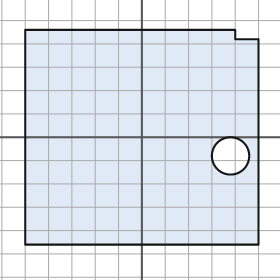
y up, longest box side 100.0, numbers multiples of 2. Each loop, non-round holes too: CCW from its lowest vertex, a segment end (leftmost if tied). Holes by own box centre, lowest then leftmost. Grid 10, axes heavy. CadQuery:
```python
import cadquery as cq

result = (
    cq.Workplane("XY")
    .moveTo(-50.0, -46.0)
    .lineTo(50.0, -46.0)
    .lineTo(50.0, 42.0)
    .lineTo(40.0, 42.0)
    .lineTo(40.0, 46.0)
    .lineTo(-50.0, 46.0)
    .close()
    .moveTo(38.0, -8.0)
    .circle(8.0)
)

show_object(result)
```